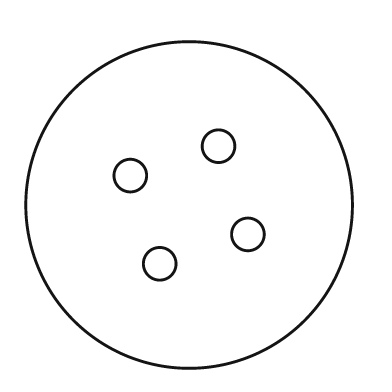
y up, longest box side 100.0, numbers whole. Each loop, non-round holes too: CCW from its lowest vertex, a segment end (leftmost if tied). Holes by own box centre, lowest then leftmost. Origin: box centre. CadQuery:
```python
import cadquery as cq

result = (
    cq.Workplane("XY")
    .moveTo(0.0, 0.0)
    .circle(50.0)
    .moveTo(-9.0, -18.0)
    .circle(5.0)
    .moveTo(18.0, -9.0)
    .circle(5.0)
    .moveTo(-18.0, 9.0)
    .circle(5.0)
    .moveTo(9.0, 18.0)
    .circle(5.0)
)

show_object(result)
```